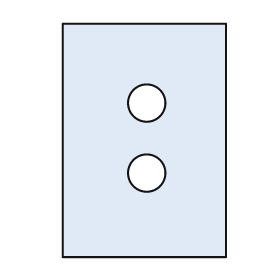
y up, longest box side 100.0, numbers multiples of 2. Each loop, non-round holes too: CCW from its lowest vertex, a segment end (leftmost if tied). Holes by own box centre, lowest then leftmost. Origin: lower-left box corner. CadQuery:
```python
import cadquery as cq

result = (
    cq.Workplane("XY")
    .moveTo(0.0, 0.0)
    .lineTo(70.0, 0.0)
    .lineTo(70.0, 100.0)
    .lineTo(0.0, 100.0)
    .close()
    .moveTo(36.0, 36.0)
    .circle(8.0)
    .moveTo(36.0, 66.0)
    .circle(8.0)
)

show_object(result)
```